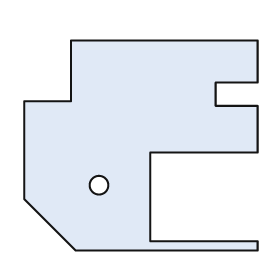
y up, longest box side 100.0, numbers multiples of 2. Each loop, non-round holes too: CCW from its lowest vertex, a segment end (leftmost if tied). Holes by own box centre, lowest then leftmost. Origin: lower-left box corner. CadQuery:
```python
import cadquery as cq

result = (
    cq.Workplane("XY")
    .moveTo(22.0, 0.0)
    .lineTo(100.0, 0.0)
    .lineTo(100.0, 4.0)
    .lineTo(54.0, 4.0)
    .lineTo(54.0, 42.0)
    .lineTo(100.0, 42.0)
    .lineTo(100.0, 62.0)
    .lineTo(82.0, 62.0)
    .lineTo(82.0, 72.0)
    .lineTo(100.0, 72.0)
    .lineTo(100.0, 90.0)
    .lineTo(20.0, 90.0)
    .lineTo(20.0, 64.0)
    .lineTo(0.0, 64.0)
    .lineTo(0.0, 22.0)
    .close()
    .moveTo(32.0, 28.0)
    .circle(4.0)
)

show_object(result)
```